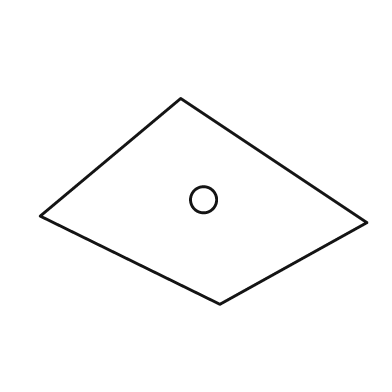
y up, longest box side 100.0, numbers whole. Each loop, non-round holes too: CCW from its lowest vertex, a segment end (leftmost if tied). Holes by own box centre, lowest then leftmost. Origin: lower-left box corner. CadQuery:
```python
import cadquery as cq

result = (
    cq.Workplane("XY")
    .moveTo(55.0, 0.0)
    .lineTo(100.0, 25.0)
    .lineTo(43.0, 63.0)
    .lineTo(0.0, 27.0)
    .close()
    .moveTo(50.0, 32.0)
    .circle(4.0)
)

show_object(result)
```